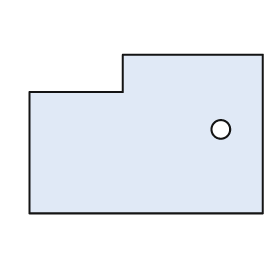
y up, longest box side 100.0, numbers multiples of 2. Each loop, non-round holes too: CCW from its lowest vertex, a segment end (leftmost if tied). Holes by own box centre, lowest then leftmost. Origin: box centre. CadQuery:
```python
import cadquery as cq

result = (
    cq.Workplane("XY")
    .moveTo(-50.0, -34.0)
    .lineTo(50.0, -34.0)
    .lineTo(50.0, 34.0)
    .lineTo(-10.0, 34.0)
    .lineTo(-10.0, 18.0)
    .lineTo(-50.0, 18.0)
    .close()
    .moveTo(32.0, 2.0)
    .circle(4.0)
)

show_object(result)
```